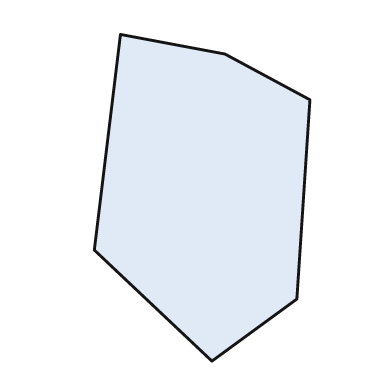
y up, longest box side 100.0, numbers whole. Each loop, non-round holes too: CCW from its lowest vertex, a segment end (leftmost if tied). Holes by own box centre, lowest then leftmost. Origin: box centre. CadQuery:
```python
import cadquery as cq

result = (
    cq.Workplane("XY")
    .moveTo(3.0, -50.0)
    .lineTo(29.0, -31.0)
    .lineTo(33.0, 30.0)
    .lineTo(7.0, 44.0)
    .lineTo(-25.0, 50.0)
    .lineTo(-33.0, -16.0)
    .close()
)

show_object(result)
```